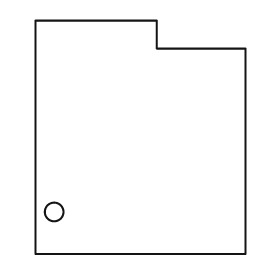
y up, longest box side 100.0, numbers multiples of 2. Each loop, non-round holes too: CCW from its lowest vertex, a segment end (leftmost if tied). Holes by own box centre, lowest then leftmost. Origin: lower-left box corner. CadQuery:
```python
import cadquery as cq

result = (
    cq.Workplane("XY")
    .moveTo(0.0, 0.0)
    .lineTo(90.0, 0.0)
    .lineTo(90.0, 88.0)
    .lineTo(52.0, 88.0)
    .lineTo(52.0, 100.0)
    .lineTo(0.0, 100.0)
    .close()
    .moveTo(8.0, 18.0)
    .circle(4.0)
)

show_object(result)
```